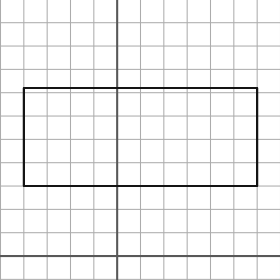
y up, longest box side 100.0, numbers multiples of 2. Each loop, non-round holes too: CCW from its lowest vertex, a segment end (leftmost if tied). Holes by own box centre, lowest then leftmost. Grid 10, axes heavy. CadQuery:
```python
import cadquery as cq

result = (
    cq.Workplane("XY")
    .moveTo(-40.0, 30.0)
    .lineTo(60.0, 30.0)
    .lineTo(60.0, 72.0)
    .lineTo(-40.0, 72.0)
    .close()
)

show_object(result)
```